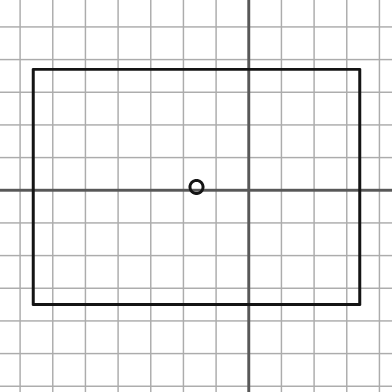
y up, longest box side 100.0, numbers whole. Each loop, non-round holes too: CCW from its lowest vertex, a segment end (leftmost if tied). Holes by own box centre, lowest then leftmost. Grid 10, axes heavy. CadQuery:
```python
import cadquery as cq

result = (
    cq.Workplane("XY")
    .moveTo(-66.0, -35.0)
    .lineTo(34.0, -35.0)
    .lineTo(34.0, 37.0)
    .lineTo(-66.0, 37.0)
    .close()
    .moveTo(-16.0, 1.0)
    .circle(2.0)
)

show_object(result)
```